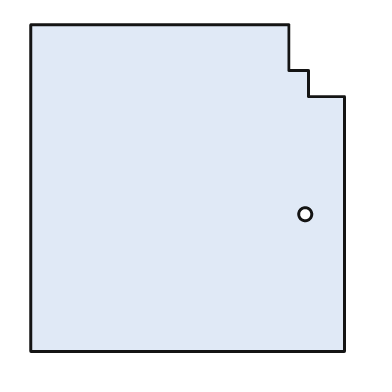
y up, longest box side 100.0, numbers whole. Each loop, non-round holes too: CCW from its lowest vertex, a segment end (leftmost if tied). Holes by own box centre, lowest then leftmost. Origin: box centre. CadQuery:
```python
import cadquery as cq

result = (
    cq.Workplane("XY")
    .moveTo(-48.0, -50.0)
    .lineTo(48.0, -50.0)
    .lineTo(48.0, 28.0)
    .lineTo(37.0, 28.0)
    .lineTo(37.0, 36.0)
    .lineTo(31.0, 36.0)
    .lineTo(31.0, 50.0)
    .lineTo(-48.0, 50.0)
    .close()
    .moveTo(36.0, -8.0)
    .circle(2.0)
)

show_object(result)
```